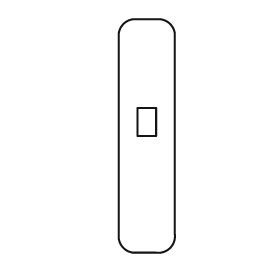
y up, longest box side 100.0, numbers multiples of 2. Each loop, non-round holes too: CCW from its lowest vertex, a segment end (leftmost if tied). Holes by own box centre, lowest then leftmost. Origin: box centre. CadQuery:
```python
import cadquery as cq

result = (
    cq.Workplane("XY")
    .moveTo(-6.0, -50.0)
    .lineTo(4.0, -50.0)
    .threePointArc((10.0, -48.0), (12.0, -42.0))
    .lineTo(12.0, 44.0)
    .threePointArc((10.0, 48.0), (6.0, 50.0))
    .lineTo(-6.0, 50.0)
    .threePointArc((-10.0, 48.0), (-12.0, 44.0))
    .lineTo(-12.0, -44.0)
    .threePointArc((-10.0, -48.0), (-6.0, -50.0))
    .close()
    .moveTo(-4.0, 0.0)
    .lineTo(4.0, 0.0)
    .lineTo(4.0, 12.0)
    .lineTo(-4.0, 12.0)
    .close()
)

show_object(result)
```